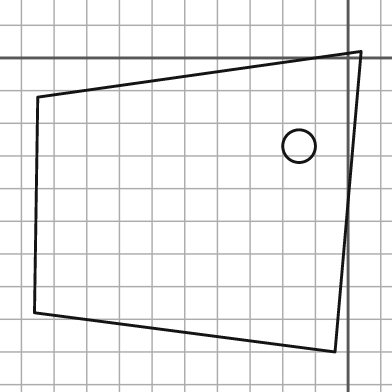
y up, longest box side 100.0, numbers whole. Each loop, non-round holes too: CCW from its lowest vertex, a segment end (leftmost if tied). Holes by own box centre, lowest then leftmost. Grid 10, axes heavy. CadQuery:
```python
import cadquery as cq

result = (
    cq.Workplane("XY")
    .moveTo(-4.0, -90.0)
    .lineTo(4.0, 2.0)
    .lineTo(-95.0, -12.0)
    .lineTo(-96.0, -78.0)
    .close()
    .moveTo(-15.0, -27.0)
    .circle(5.0)
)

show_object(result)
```